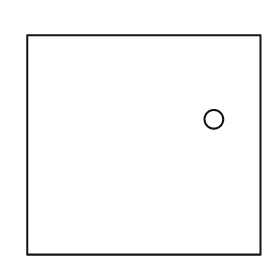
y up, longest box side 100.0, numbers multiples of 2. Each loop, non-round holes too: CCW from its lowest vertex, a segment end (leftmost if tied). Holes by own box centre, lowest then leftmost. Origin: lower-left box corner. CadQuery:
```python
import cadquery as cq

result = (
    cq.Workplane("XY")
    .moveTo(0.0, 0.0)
    .lineTo(100.0, 0.0)
    .lineTo(100.0, 94.0)
    .lineTo(0.0, 94.0)
    .close()
    .moveTo(80.0, 58.0)
    .circle(4.0)
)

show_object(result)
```